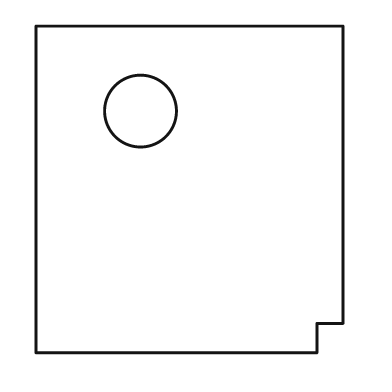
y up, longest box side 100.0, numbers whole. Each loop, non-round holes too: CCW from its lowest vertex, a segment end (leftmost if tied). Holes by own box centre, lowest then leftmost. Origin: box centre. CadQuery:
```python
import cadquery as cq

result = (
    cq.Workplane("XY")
    .moveTo(-47.0, -50.0)
    .lineTo(39.0, -50.0)
    .lineTo(39.0, -41.0)
    .lineTo(47.0, -41.0)
    .lineTo(47.0, 50.0)
    .lineTo(-47.0, 50.0)
    .close()
    .moveTo(-15.0, 24.0)
    .circle(11.0)
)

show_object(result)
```